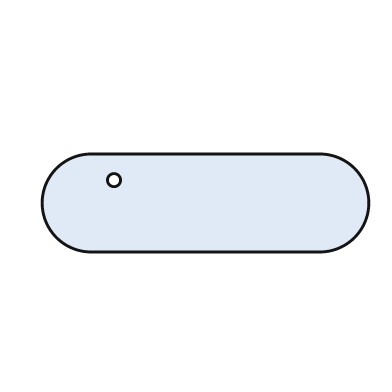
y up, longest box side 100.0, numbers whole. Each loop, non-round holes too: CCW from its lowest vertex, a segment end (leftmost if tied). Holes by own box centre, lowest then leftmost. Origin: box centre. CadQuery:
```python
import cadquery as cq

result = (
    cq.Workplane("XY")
    .moveTo(-35.0, -15.0)
    .lineTo(35.0, -15.0)
    .threePointArc((50.0, 0.0), (35.0, 15.0))
    .lineTo(-35.0, 15.0)
    .threePointArc((-50.0, 0.0), (-35.0, -15.0))
    .close()
    .moveTo(-28.0, 7.0)
    .circle(2.0)
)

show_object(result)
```